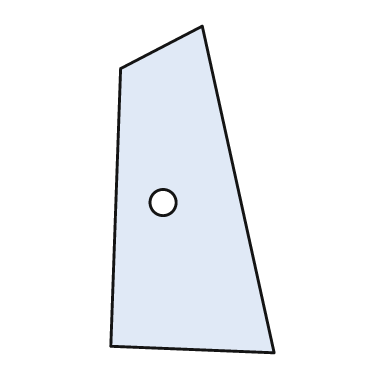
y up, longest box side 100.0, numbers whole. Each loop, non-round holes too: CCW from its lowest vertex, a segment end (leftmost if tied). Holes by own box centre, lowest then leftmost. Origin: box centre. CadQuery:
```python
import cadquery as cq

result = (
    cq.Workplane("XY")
    .moveTo(25.0, -50.0)
    .lineTo(3.0, 50.0)
    .lineTo(-22.0, 37.0)
    .lineTo(-25.0, -48.0)
    .close()
    .moveTo(-9.0, -4.0)
    .circle(4.0)
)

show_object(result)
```